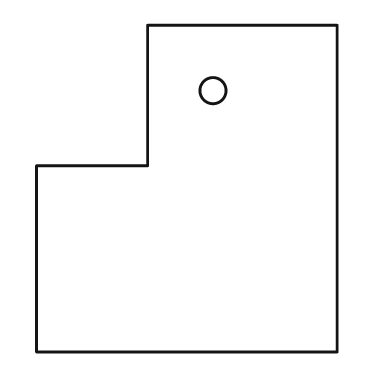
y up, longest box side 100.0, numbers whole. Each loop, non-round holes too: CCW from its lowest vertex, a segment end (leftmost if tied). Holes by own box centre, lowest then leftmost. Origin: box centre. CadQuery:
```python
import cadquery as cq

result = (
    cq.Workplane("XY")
    .moveTo(-46.0, -50.0)
    .lineTo(46.0, -50.0)
    .lineTo(46.0, 50.0)
    .lineTo(-12.0, 50.0)
    .lineTo(-12.0, 7.0)
    .lineTo(-46.0, 7.0)
    .close()
    .moveTo(8.0, 30.0)
    .circle(4.0)
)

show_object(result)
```